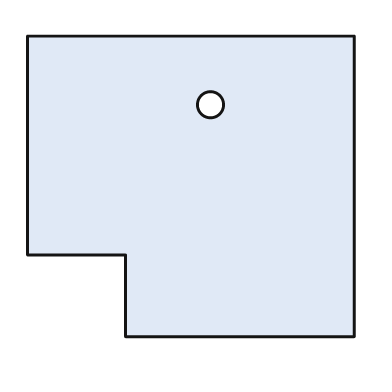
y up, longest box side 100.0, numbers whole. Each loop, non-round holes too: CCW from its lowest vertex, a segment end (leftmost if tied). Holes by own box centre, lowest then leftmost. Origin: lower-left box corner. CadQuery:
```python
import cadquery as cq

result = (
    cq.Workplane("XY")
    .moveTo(30.0, 0.0)
    .lineTo(100.0, 0.0)
    .lineTo(100.0, 92.0)
    .lineTo(0.0, 92.0)
    .lineTo(0.0, 25.0)
    .lineTo(30.0, 25.0)
    .close()
    .moveTo(56.0, 71.0)
    .circle(4.0)
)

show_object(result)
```